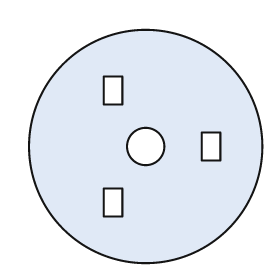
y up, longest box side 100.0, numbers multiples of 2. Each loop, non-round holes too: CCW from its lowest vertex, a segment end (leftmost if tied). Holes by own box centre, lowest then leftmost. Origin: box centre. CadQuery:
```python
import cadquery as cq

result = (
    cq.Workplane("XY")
    .moveTo(0.0, 0.0)
    .circle(50.0)
    .moveTo(-18.0, -30.0)
    .lineTo(-10.0, -30.0)
    .lineTo(-10.0, -18.0)
    .lineTo(-18.0, -18.0)
    .close()
    .moveTo(0.0, 0.0)
    .circle(8.0)
    .moveTo(24.0, -6.0)
    .lineTo(32.0, -6.0)
    .lineTo(32.0, 6.0)
    .lineTo(24.0, 6.0)
    .close()
    .moveTo(-18.0, 18.0)
    .lineTo(-10.0, 18.0)
    .lineTo(-10.0, 30.0)
    .lineTo(-18.0, 30.0)
    .close()
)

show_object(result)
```